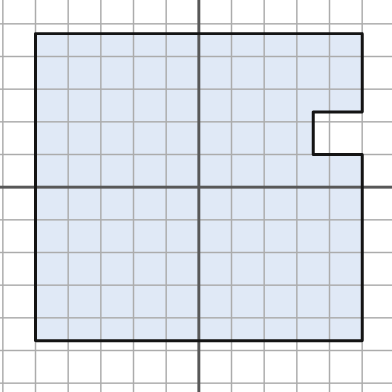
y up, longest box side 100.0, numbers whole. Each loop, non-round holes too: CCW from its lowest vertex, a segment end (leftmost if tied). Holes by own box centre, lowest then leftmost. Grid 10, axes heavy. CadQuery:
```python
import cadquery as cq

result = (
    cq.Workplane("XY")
    .moveTo(-50.0, -47.0)
    .lineTo(50.0, -47.0)
    .lineTo(50.0, 10.0)
    .lineTo(35.0, 10.0)
    .lineTo(35.0, 23.0)
    .lineTo(50.0, 23.0)
    .lineTo(50.0, 47.0)
    .lineTo(-50.0, 47.0)
    .close()
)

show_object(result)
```